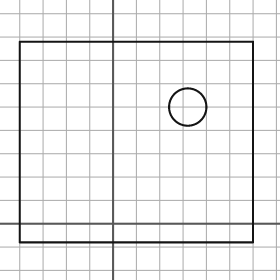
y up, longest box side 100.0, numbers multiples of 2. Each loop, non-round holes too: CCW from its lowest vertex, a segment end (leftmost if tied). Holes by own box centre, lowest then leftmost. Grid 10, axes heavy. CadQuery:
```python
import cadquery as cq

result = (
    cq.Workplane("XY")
    .moveTo(-40.0, -8.0)
    .lineTo(60.0, -8.0)
    .lineTo(60.0, 78.0)
    .lineTo(-40.0, 78.0)
    .close()
    .moveTo(32.0, 50.0)
    .circle(8.0)
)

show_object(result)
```